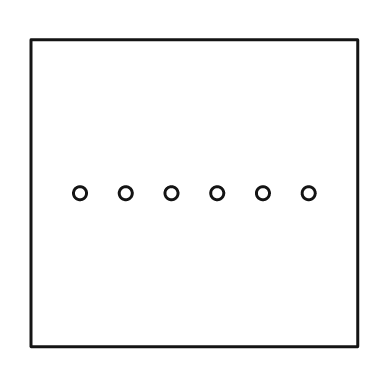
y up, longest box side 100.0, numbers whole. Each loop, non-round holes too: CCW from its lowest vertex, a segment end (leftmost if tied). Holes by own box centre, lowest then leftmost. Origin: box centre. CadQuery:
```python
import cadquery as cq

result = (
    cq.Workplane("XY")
    .moveTo(-50.0, -47.0)
    .lineTo(50.0, -47.0)
    .lineTo(50.0, 47.0)
    .lineTo(-50.0, 47.0)
    .close()
    .moveTo(-35.0, 0.0)
    .circle(2.0)
    .moveTo(-21.0, 0.0)
    .circle(2.0)
    .moveTo(-7.0, 0.0)
    .circle(2.0)
    .moveTo(7.0, 0.0)
    .circle(2.0)
    .moveTo(21.0, 0.0)
    .circle(2.0)
    .moveTo(35.0, 0.0)
    .circle(2.0)
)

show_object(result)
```